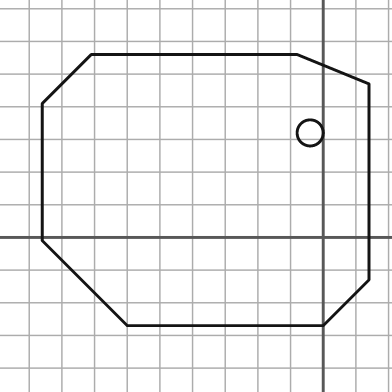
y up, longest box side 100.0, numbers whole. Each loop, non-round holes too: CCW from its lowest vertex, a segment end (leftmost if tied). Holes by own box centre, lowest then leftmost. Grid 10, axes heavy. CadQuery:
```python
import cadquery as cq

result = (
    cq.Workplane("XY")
    .moveTo(-60.0, -27.0)
    .lineTo(0.0, -27.0)
    .lineTo(14.0, -13.0)
    .lineTo(14.0, 47.0)
    .lineTo(-8.0, 56.0)
    .lineTo(-71.0, 56.0)
    .lineTo(-86.0, 41.0)
    .lineTo(-86.0, -1.0)
    .close()
    .moveTo(-4.0, 32.0)
    .circle(4.0)
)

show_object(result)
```